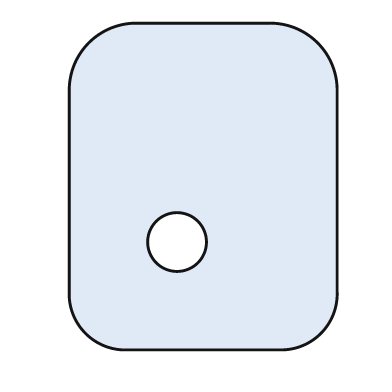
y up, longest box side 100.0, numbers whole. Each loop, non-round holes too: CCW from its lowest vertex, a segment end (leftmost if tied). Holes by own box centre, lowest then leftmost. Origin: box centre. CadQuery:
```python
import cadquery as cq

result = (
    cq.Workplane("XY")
    .moveTo(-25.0, -50.0)
    .lineTo(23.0, -50.0)
    .threePointArc((36.0, -45.0), (41.0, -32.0))
    .lineTo(41.0, 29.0)
    .threePointArc((35.0, 44.0), (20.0, 50.0))
    .lineTo(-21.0, 50.0)
    .threePointArc((-35.0, 44.0), (-41.0, 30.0))
    .lineTo(-41.0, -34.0)
    .threePointArc((-36.0, -45.0), (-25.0, -50.0))
    .close()
    .moveTo(-8.0, -17.0)
    .circle(9.0)
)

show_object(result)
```